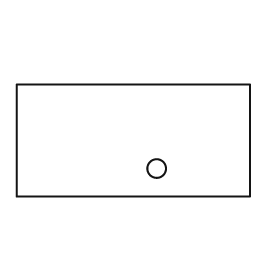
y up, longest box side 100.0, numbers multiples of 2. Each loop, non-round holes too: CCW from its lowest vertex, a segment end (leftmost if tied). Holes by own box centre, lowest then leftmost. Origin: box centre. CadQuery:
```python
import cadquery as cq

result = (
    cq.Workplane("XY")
    .moveTo(-50.0, -24.0)
    .lineTo(50.0, -24.0)
    .lineTo(50.0, 24.0)
    .lineTo(-50.0, 24.0)
    .close()
    .moveTo(10.0, -12.0)
    .circle(4.0)
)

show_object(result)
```